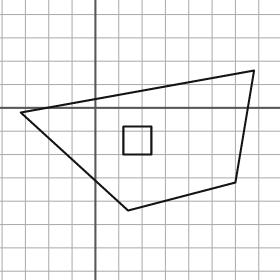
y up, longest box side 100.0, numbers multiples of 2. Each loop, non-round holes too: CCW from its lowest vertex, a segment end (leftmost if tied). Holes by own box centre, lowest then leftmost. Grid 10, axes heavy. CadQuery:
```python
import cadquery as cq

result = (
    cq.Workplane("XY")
    .moveTo(14.0, -44.0)
    .lineTo(60.0, -32.0)
    .lineTo(68.0, 16.0)
    .lineTo(-32.0, -2.0)
    .close()
    .moveTo(12.0, -20.0)
    .lineTo(24.0, -20.0)
    .lineTo(24.0, -8.0)
    .lineTo(12.0, -8.0)
    .close()
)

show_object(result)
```